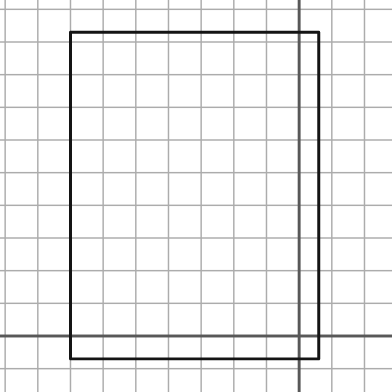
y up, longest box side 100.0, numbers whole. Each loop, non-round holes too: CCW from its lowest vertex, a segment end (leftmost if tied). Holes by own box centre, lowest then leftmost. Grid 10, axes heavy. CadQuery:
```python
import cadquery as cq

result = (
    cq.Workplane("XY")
    .moveTo(-70.0, -7.0)
    .lineTo(6.0, -7.0)
    .lineTo(6.0, 93.0)
    .lineTo(-70.0, 93.0)
    .close()
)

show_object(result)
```